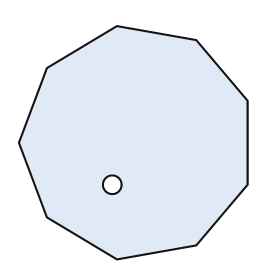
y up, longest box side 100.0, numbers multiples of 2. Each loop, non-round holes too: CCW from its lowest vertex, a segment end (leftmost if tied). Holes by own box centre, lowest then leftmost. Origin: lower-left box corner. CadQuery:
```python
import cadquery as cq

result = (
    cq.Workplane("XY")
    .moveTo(42.0, 0.0)
    .lineTo(76.0, 6.0)
    .lineTo(98.0, 32.0)
    .lineTo(98.0, 68.0)
    .lineTo(76.0, 94.0)
    .lineTo(42.0, 100.0)
    .lineTo(12.0, 82.0)
    .lineTo(0.0, 50.0)
    .lineTo(12.0, 18.0)
    .close()
    .moveTo(40.0, 32.0)
    .circle(4.0)
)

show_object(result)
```